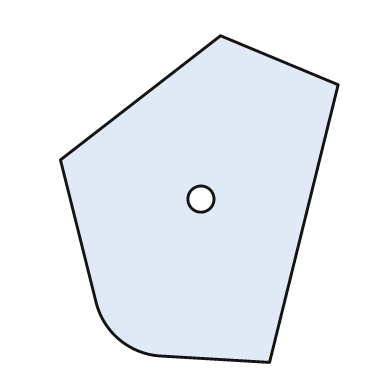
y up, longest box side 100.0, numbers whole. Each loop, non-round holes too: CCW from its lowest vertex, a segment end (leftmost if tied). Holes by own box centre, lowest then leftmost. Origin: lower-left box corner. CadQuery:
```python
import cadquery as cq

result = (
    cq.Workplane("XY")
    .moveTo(64.0, 0.0)
    .lineTo(85.0, 85.0)
    .lineTo(49.0, 100.0)
    .lineTo(0.0, 62.0)
    .lineTo(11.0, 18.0)
    .threePointArc((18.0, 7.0), (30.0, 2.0))
    .close()
    .moveTo(43.0, 50.0)
    .circle(4.0)
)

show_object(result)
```